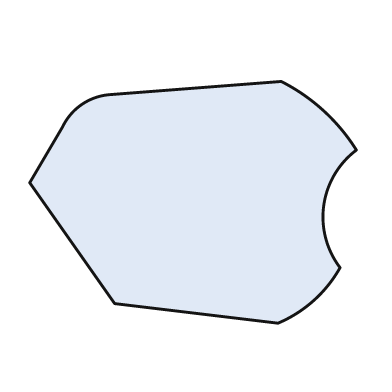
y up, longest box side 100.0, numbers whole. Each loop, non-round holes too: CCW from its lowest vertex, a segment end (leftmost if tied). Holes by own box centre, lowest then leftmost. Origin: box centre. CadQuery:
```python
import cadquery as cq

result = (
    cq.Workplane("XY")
    .moveTo(26.0, -37.0)
    .threePointArc((37.0, -30.0), (45.0, -20.0))
    .threePointArc((40.0, -1.0), (50.0, 16.0))
    .threePointArc((40.0, 28.0), (27.0, 37.0))
    .lineTo(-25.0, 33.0)
    .threePointArc((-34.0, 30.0), (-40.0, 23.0))
    .lineTo(-50.0, 6.0)
    .lineTo(-24.0, -31.0)
    .close()
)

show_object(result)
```